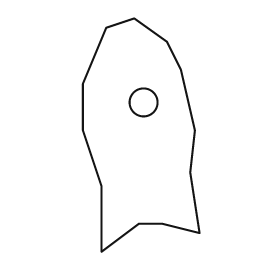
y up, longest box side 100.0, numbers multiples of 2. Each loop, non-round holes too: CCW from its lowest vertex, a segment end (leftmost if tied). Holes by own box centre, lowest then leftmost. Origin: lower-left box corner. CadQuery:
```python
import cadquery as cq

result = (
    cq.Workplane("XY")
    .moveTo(8.0, 0.0)
    .lineTo(24.0, 12.0)
    .lineTo(34.0, 12.0)
    .lineTo(50.0, 8.0)
    .lineTo(46.0, 34.0)
    .lineTo(48.0, 52.0)
    .lineTo(42.0, 78.0)
    .lineTo(36.0, 90.0)
    .lineTo(22.0, 100.0)
    .lineTo(10.0, 96.0)
    .lineTo(0.0, 72.0)
    .lineTo(0.0, 52.0)
    .lineTo(8.0, 28.0)
    .close()
    .moveTo(26.0, 64.0)
    .circle(6.0)
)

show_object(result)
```